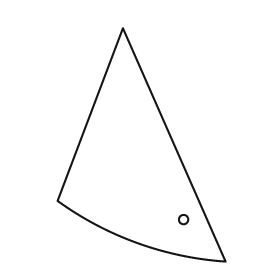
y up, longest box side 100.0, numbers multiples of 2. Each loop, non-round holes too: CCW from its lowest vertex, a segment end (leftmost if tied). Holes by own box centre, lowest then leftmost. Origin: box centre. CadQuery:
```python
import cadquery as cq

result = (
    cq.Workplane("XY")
    .moveTo(36.0, -50.0)
    .lineTo(-8.0, 50.0)
    .lineTo(-36.0, -24.0)
    .threePointArc((-2.0, -42.0), (36.0, -50.0))
    .close()
    .moveTo(18.0, -32.0)
    .circle(2.0)
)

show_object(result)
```